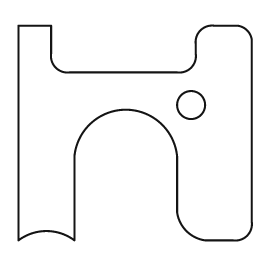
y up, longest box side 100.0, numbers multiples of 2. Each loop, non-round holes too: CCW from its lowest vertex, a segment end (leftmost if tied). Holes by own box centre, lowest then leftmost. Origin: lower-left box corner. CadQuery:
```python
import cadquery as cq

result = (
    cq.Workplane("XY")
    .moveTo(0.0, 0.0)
    .threePointArc((12.0, 4.0), (24.0, 0.0))
    .lineTo(24.0, 36.0)
    .threePointArc((46.0, 56.0), (68.0, 36.0))
    .lineTo(68.0, 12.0)
    .threePointArc((72.0, 4.0), (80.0, 0.0))
    .lineTo(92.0, 0.0)
    .threePointArc((98.0, 2.0), (100.0, 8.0))
    .lineTo(100.0, 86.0)
    .threePointArc((98.0, 90.0), (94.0, 92.0))
    .lineTo(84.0, 92.0)
    .threePointArc((78.0, 90.0), (76.0, 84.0))
    .lineTo(76.0, 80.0)
    .threePointArc((74.0, 74.0), (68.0, 72.0))
    .lineTo(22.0, 72.0)
    .threePointArc((16.0, 74.0), (14.0, 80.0))
    .lineTo(14.0, 92.0)
    .lineTo(0.0, 92.0)
    .close()
    .moveTo(74.0, 58.0)
    .circle(6.0)
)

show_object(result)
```